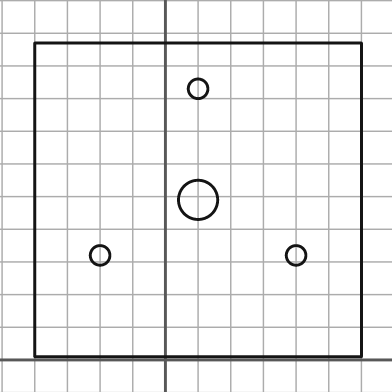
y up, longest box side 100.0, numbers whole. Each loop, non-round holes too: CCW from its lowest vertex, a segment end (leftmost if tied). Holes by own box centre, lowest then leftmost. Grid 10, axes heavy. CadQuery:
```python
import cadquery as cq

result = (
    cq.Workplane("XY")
    .moveTo(-40.0, 1.0)
    .lineTo(60.0, 1.0)
    .lineTo(60.0, 97.0)
    .lineTo(-40.0, 97.0)
    .close()
    .moveTo(-20.0, 32.0)
    .circle(3.0)
    .moveTo(40.0, 32.0)
    .circle(3.0)
    .moveTo(10.0, 49.0)
    .circle(6.0)
    .moveTo(10.0, 83.0)
    .circle(3.0)
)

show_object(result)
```